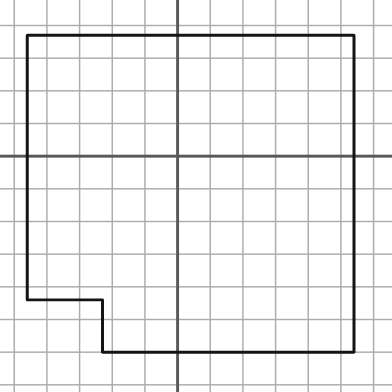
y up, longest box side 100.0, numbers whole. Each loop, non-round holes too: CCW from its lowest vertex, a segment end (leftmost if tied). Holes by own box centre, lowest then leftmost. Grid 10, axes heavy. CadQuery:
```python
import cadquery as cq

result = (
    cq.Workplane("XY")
    .moveTo(-23.0, -60.0)
    .lineTo(54.0, -60.0)
    .lineTo(54.0, 37.0)
    .lineTo(-46.0, 37.0)
    .lineTo(-46.0, -44.0)
    .lineTo(-23.0, -44.0)
    .close()
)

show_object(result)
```